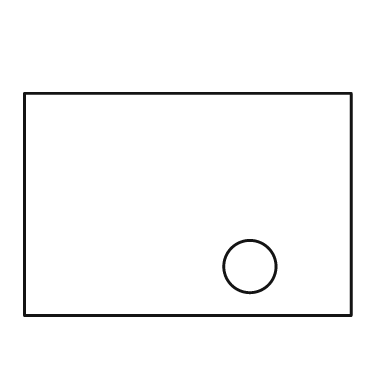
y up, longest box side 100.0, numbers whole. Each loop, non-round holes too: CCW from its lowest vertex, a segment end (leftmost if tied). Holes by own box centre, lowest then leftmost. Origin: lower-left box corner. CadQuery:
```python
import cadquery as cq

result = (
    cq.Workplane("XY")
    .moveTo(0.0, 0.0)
    .lineTo(100.0, 0.0)
    .lineTo(100.0, 68.0)
    .lineTo(0.0, 68.0)
    .close()
    .moveTo(69.0, 15.0)
    .circle(8.0)
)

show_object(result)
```